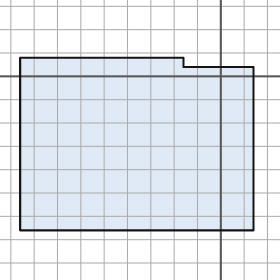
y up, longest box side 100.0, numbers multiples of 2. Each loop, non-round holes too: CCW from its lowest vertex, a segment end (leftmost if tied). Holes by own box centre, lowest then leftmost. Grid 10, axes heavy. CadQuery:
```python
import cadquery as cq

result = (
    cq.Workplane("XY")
    .moveTo(-86.0, -66.0)
    .lineTo(14.0, -66.0)
    .lineTo(14.0, 4.0)
    .lineTo(-16.0, 4.0)
    .lineTo(-16.0, 8.0)
    .lineTo(-86.0, 8.0)
    .close()
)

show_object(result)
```